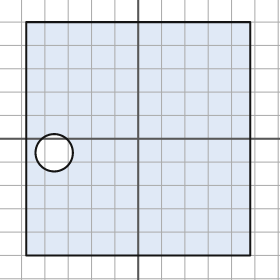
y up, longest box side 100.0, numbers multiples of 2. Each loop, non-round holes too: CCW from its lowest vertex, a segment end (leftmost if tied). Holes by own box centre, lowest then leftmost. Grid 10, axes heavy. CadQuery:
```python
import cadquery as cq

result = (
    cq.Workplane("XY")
    .moveTo(-48.0, -50.0)
    .lineTo(48.0, -50.0)
    .lineTo(48.0, 50.0)
    .lineTo(-48.0, 50.0)
    .close()
    .moveTo(-36.0, -6.0)
    .circle(8.0)
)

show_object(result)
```